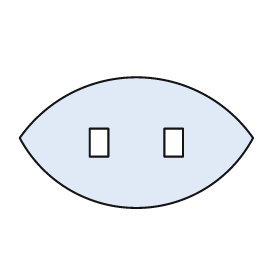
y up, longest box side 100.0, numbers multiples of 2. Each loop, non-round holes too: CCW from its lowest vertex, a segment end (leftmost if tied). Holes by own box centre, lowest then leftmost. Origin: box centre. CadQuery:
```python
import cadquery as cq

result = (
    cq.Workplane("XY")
    .moveTo(-50.0, 2.0)
    .threePointArc((0.0, -28.0), (50.0, 2.0))
    .threePointArc((0.0, 28.0), (-50.0, 2.0))
    .close()
    .moveTo(-20.0, -6.0)
    .lineTo(-12.0, -6.0)
    .lineTo(-12.0, 6.0)
    .lineTo(-20.0, 6.0)
    .close()
    .moveTo(12.0, -6.0)
    .lineTo(20.0, -6.0)
    .lineTo(20.0, 6.0)
    .lineTo(12.0, 6.0)
    .close()
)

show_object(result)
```